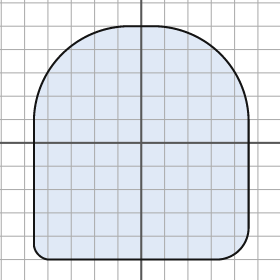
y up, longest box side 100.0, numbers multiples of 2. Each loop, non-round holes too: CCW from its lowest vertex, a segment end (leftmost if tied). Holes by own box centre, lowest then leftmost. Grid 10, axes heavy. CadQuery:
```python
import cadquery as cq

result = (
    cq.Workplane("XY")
    .moveTo(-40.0, -50.0)
    .lineTo(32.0, -50.0)
    .threePointArc((42.0, -46.0), (46.0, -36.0))
    .lineTo(46.0, 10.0)
    .threePointArc((34.0, 38.0), (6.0, 50.0))
    .lineTo(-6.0, 50.0)
    .threePointArc((-34.0, 38.0), (-46.0, 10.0))
    .lineTo(-46.0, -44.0)
    .threePointArc((-44.0, -48.0), (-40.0, -50.0))
    .close()
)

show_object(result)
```